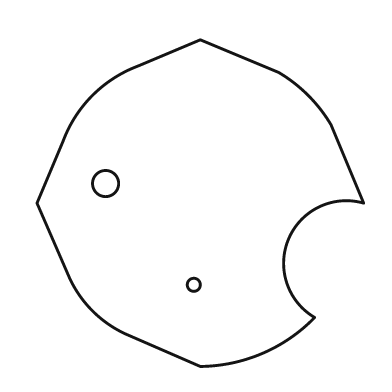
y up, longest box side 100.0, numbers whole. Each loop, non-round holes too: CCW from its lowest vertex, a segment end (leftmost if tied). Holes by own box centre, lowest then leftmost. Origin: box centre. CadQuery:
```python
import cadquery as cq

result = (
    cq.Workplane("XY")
    .moveTo(0.0, -50.0)
    .threePointArc((19.0, -46.0), (35.0, -35.0))
    .threePointArc((27.0, -11.0), (50.0, 0.0))
    .lineTo(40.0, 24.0)
    .threePointArc((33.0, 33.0), (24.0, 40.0))
    .lineTo(0.0, 50.0)
    .lineTo(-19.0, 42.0)
    .threePointArc((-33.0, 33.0), (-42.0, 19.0))
    .lineTo(-50.0, 0.0)
    .lineTo(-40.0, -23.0)
    .threePointArc((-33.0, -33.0), (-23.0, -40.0))
    .close()
    .moveTo(-2.0, -25.0)
    .circle(2.0)
    .moveTo(-29.0, 6.0)
    .circle(4.0)
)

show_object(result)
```